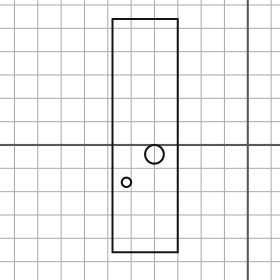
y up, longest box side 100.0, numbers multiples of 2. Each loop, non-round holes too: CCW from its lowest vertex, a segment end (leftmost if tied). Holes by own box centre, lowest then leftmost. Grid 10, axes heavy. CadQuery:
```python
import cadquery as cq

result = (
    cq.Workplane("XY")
    .moveTo(-58.0, -46.0)
    .lineTo(-30.0, -46.0)
    .lineTo(-30.0, 54.0)
    .lineTo(-58.0, 54.0)
    .close()
    .moveTo(-52.0, -16.0)
    .circle(2.0)
    .moveTo(-40.0, -4.0)
    .circle(4.0)
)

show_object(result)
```